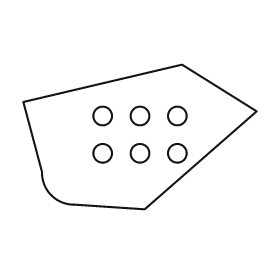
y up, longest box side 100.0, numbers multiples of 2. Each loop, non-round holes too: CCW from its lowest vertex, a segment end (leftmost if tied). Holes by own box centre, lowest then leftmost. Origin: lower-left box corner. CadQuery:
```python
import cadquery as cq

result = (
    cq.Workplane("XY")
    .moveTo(52.0, 0.0)
    .lineTo(100.0, 42.0)
    .lineTo(68.0, 62.0)
    .lineTo(0.0, 46.0)
    .lineTo(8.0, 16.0)
    .threePointArc((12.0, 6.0), (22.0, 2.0))
    .close()
    .moveTo(34.0, 24.0)
    .circle(4.0)
    .moveTo(50.0, 24.0)
    .circle(4.0)
    .moveTo(66.0, 24.0)
    .circle(4.0)
    .moveTo(34.0, 40.0)
    .circle(4.0)
    .moveTo(50.0, 40.0)
    .circle(4.0)
    .moveTo(66.0, 40.0)
    .circle(4.0)
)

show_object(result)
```